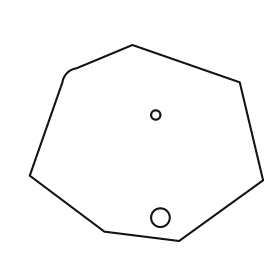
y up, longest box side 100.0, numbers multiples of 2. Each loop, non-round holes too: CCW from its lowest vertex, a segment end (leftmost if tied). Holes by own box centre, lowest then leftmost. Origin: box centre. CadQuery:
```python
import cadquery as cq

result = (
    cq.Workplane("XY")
    .moveTo(14.0, -42.0)
    .lineTo(50.0, -16.0)
    .lineTo(40.0, 26.0)
    .lineTo(-6.0, 42.0)
    .lineTo(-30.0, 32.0)
    .threePointArc((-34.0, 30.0), (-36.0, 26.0))
    .lineTo(-50.0, -14.0)
    .lineTo(-18.0, -38.0)
    .close()
    .moveTo(6.0, -32.0)
    .circle(4.0)
    .moveTo(4.0, 12.0)
    .circle(2.0)
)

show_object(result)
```